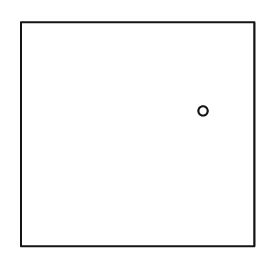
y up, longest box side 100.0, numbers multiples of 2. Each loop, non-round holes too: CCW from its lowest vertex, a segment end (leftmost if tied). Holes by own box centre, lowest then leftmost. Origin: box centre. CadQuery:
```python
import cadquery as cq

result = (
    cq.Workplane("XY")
    .moveTo(-50.0, -48.0)
    .lineTo(50.0, -48.0)
    .lineTo(50.0, 48.0)
    .lineTo(-50.0, 48.0)
    .close()
    .moveTo(28.0, 10.0)
    .circle(2.0)
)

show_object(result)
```